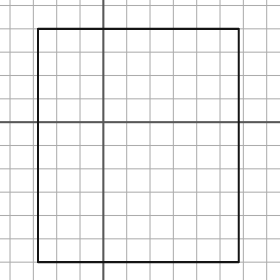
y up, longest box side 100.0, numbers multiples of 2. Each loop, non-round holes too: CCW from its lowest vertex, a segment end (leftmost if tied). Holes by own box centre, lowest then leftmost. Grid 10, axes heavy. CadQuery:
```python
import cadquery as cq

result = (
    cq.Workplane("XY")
    .moveTo(-28.0, -60.0)
    .lineTo(58.0, -60.0)
    .lineTo(58.0, 40.0)
    .lineTo(-28.0, 40.0)
    .close()
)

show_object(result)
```